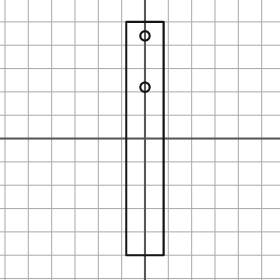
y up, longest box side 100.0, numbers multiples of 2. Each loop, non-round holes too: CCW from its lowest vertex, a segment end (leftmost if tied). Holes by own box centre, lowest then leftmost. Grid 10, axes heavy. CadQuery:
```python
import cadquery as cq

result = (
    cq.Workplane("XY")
    .moveTo(-8.0, -50.0)
    .lineTo(8.0, -50.0)
    .lineTo(8.0, 50.0)
    .lineTo(-8.0, 50.0)
    .close()
    .moveTo(0.0, 22.0)
    .circle(2.0)
    .moveTo(0.0, 44.0)
    .circle(2.0)
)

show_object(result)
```